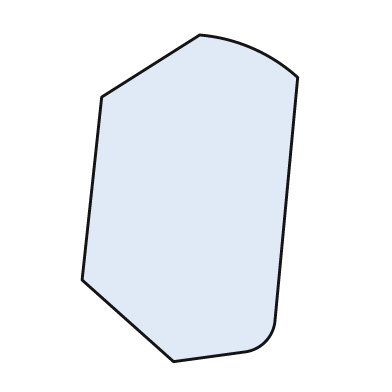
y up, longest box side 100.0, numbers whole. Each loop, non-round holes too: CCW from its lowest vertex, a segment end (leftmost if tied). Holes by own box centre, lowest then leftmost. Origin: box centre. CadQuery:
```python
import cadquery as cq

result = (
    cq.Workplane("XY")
    .moveTo(-5.0, -50.0)
    .lineTo(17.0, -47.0)
    .threePointArc((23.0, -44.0), (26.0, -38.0))
    .lineTo(33.0, 37.0)
    .threePointArc((19.0, 46.0), (3.0, 50.0))
    .lineTo(-27.0, 31.0)
    .lineTo(-33.0, -25.0)
    .close()
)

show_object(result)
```